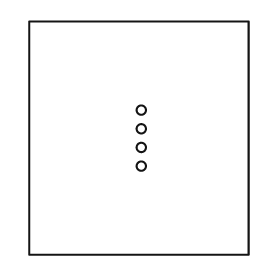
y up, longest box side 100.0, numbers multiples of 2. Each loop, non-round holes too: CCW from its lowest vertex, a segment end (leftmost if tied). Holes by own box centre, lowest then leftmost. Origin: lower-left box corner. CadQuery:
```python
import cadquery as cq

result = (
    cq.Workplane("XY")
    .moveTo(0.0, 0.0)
    .lineTo(94.0, 0.0)
    .lineTo(94.0, 100.0)
    .lineTo(0.0, 100.0)
    .close()
    .moveTo(48.0, 38.0)
    .circle(2.0)
    .moveTo(48.0, 46.0)
    .circle(2.0)
    .moveTo(48.0, 54.0)
    .circle(2.0)
    .moveTo(48.0, 62.0)
    .circle(2.0)
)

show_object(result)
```